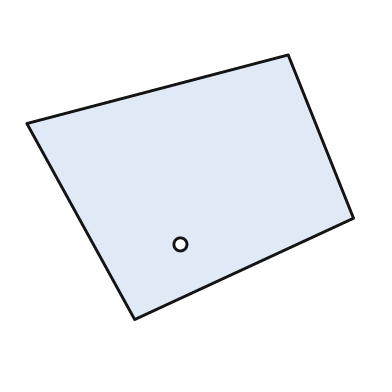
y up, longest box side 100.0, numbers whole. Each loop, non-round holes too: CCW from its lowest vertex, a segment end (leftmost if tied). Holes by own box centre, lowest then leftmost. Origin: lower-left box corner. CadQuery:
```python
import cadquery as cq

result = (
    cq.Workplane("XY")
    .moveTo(33.0, 0.0)
    .lineTo(100.0, 31.0)
    .lineTo(80.0, 81.0)
    .lineTo(0.0, 60.0)
    .close()
    .moveTo(47.0, 23.0)
    .circle(2.0)
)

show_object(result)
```